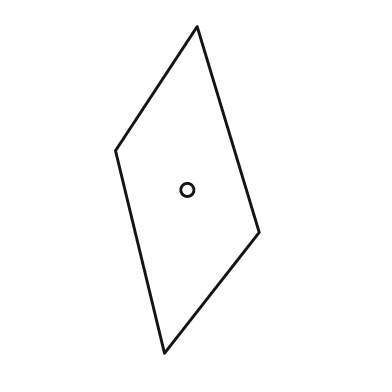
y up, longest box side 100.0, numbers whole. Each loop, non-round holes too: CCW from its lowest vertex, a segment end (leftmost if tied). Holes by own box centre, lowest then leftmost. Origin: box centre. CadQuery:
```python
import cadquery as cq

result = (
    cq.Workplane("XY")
    .moveTo(-7.0, -50.0)
    .lineTo(22.0, -13.0)
    .lineTo(3.0, 50.0)
    .lineTo(-22.0, 12.0)
    .close()
    .moveTo(0.0, 0.0)
    .circle(2.0)
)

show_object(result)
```